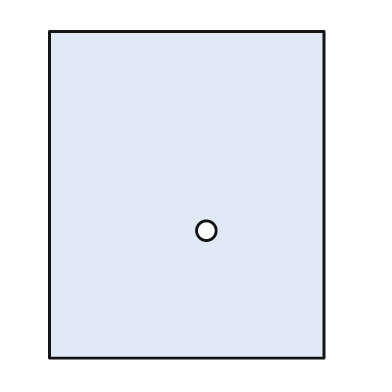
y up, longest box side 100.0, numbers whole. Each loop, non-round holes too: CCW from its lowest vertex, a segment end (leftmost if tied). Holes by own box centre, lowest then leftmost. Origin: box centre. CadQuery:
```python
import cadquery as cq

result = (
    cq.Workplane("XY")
    .moveTo(-42.0, -50.0)
    .lineTo(42.0, -50.0)
    .lineTo(42.0, 50.0)
    .lineTo(-42.0, 50.0)
    .close()
    .moveTo(6.0, -11.0)
    .circle(3.0)
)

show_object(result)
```